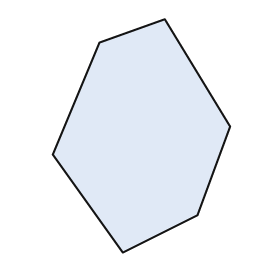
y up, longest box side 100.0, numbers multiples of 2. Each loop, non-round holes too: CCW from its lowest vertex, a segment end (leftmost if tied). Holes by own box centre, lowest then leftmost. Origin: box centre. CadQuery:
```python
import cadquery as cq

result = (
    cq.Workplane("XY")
    .moveTo(-8.0, -50.0)
    .lineTo(24.0, -34.0)
    .lineTo(38.0, 4.0)
    .lineTo(10.0, 50.0)
    .lineTo(-18.0, 40.0)
    .lineTo(-38.0, -8.0)
    .close()
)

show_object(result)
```